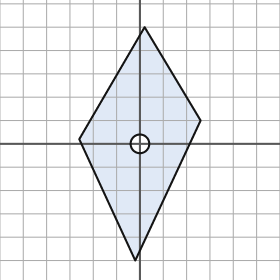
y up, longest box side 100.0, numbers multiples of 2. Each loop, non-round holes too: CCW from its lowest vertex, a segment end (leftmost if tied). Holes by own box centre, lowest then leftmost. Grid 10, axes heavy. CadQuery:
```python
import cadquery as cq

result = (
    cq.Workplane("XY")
    .moveTo(-2.0, -50.0)
    .lineTo(26.0, 10.0)
    .lineTo(2.0, 50.0)
    .lineTo(-26.0, 2.0)
    .close()
    .moveTo(0.0, 0.0)
    .circle(4.0)
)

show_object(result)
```